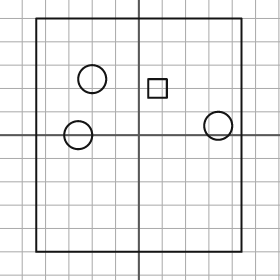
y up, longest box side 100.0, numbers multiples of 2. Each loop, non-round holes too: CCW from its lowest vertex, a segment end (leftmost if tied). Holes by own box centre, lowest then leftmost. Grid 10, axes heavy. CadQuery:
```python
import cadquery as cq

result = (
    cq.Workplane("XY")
    .moveTo(-44.0, -50.0)
    .lineTo(44.0, -50.0)
    .lineTo(44.0, 50.0)
    .lineTo(-44.0, 50.0)
    .close()
    .moveTo(-26.0, 0.0)
    .circle(6.0)
    .moveTo(34.0, 4.0)
    .circle(6.0)
    .moveTo(4.0, 16.0)
    .lineTo(12.0, 16.0)
    .lineTo(12.0, 24.0)
    .lineTo(4.0, 24.0)
    .close()
    .moveTo(-20.0, 24.0)
    .circle(6.0)
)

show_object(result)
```